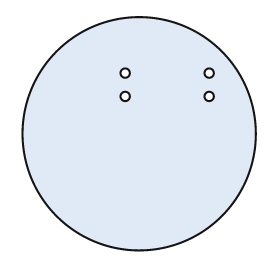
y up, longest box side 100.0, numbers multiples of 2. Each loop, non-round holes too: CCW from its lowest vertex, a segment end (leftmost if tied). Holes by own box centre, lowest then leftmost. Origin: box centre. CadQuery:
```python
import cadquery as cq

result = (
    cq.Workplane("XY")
    .moveTo(0.0, 0.0)
    .circle(50.0)
    .moveTo(-6.0, 16.0)
    .circle(2.0)
    .moveTo(30.0, 16.0)
    .circle(2.0)
    .moveTo(-6.0, 26.0)
    .circle(2.0)
    .moveTo(30.0, 26.0)
    .circle(2.0)
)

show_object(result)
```